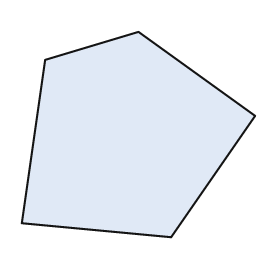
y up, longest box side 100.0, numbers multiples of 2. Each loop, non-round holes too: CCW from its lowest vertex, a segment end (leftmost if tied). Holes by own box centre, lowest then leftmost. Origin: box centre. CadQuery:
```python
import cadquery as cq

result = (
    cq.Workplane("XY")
    .moveTo(14.0, -44.0)
    .lineTo(50.0, 8.0)
    .lineTo(0.0, 44.0)
    .lineTo(-40.0, 32.0)
    .lineTo(-50.0, -38.0)
    .close()
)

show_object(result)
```